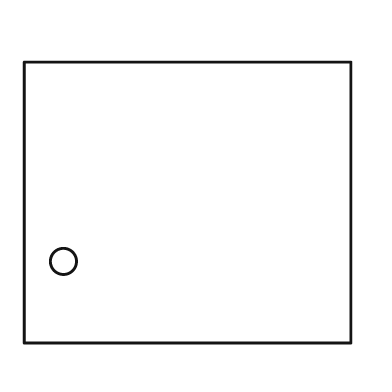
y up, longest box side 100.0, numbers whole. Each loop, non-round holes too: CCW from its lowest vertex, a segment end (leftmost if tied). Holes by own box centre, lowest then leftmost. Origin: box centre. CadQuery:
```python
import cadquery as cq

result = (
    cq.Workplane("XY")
    .moveTo(-50.0, -43.0)
    .lineTo(50.0, -43.0)
    .lineTo(50.0, 43.0)
    .lineTo(-50.0, 43.0)
    .close()
    .moveTo(-38.0, -18.0)
    .circle(4.0)
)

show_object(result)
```